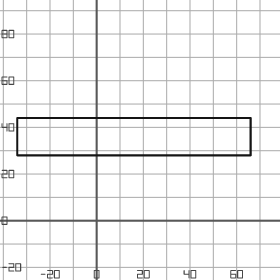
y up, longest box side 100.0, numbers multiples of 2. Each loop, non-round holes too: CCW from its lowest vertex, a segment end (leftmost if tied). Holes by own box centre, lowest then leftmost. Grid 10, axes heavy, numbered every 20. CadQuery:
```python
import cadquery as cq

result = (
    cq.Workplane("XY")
    .moveTo(-34.0, 28.0)
    .lineTo(66.0, 28.0)
    .lineTo(66.0, 44.0)
    .lineTo(-34.0, 44.0)
    .close()
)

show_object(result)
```